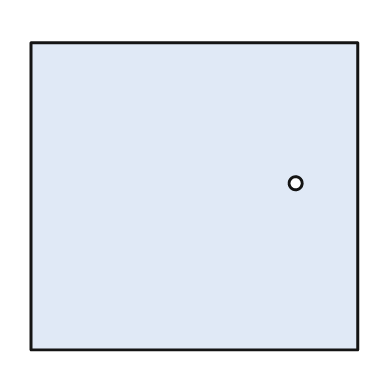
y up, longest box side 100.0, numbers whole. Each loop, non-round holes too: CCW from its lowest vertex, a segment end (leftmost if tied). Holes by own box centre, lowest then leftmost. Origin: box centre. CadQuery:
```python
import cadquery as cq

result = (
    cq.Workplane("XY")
    .moveTo(-50.0, -47.0)
    .lineTo(50.0, -47.0)
    .lineTo(50.0, 47.0)
    .lineTo(-50.0, 47.0)
    .close()
    .moveTo(31.0, 4.0)
    .circle(2.0)
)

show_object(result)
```